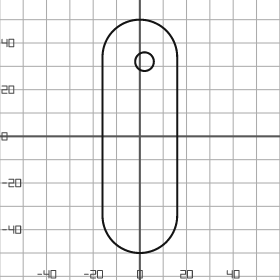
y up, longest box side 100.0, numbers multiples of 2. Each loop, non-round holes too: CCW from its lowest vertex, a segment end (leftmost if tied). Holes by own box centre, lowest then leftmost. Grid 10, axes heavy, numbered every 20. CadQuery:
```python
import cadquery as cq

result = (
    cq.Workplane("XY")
    .moveTo(-16.0, -34.0)
    .threePointArc((0.0, -50.0), (16.0, -34.0))
    .lineTo(16.0, 34.0)
    .threePointArc((0.0, 50.0), (-16.0, 34.0))
    .close()
    .moveTo(2.0, 32.0)
    .circle(4.0)
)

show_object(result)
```